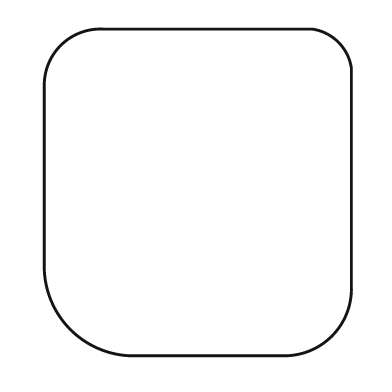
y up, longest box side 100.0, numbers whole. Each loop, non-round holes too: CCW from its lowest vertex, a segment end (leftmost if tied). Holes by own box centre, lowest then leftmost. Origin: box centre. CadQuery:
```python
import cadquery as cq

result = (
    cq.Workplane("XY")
    .moveTo(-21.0, -50.0)
    .lineTo(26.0, -50.0)
    .threePointArc((41.0, -44.0), (47.0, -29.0))
    .lineTo(47.0, 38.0)
    .threePointArc((43.0, 46.0), (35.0, 50.0))
    .lineTo(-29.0, 50.0)
    .threePointArc((-42.0, 45.0), (-47.0, 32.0))
    .lineTo(-47.0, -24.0)
    .threePointArc((-39.0, -42.0), (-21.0, -50.0))
    .close()
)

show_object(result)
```